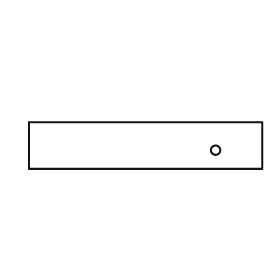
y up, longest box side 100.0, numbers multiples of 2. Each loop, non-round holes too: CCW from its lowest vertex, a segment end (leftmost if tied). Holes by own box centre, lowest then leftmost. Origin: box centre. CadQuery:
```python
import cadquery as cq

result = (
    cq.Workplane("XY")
    .moveTo(-50.0, -10.0)
    .lineTo(50.0, -10.0)
    .lineTo(50.0, 10.0)
    .lineTo(-50.0, 10.0)
    .close()
    .moveTo(30.0, -2.0)
    .circle(2.0)
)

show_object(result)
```